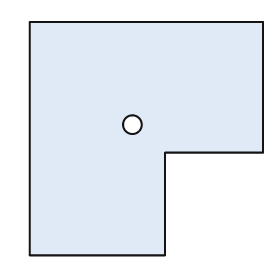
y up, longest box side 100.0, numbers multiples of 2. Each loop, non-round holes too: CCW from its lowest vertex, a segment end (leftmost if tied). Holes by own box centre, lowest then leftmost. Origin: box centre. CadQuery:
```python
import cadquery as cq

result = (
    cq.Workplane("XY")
    .moveTo(-50.0, -50.0)
    .lineTo(8.0, -50.0)
    .lineTo(8.0, -6.0)
    .lineTo(50.0, -6.0)
    .lineTo(50.0, 50.0)
    .lineTo(-50.0, 50.0)
    .close()
    .moveTo(-6.0, 6.0)
    .circle(4.0)
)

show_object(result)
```